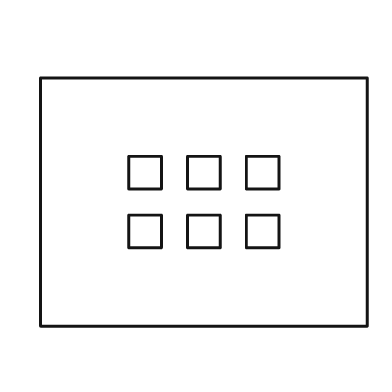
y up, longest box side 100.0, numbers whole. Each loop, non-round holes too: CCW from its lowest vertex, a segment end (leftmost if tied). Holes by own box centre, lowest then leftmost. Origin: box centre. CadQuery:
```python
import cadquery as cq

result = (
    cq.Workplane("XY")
    .moveTo(-50.0, -38.0)
    .lineTo(50.0, -38.0)
    .lineTo(50.0, 38.0)
    .lineTo(-50.0, 38.0)
    .close()
    .moveTo(-23.0, -14.0)
    .lineTo(-13.0, -14.0)
    .lineTo(-13.0, -4.0)
    .lineTo(-23.0, -4.0)
    .close()
    .moveTo(-5.0, -14.0)
    .lineTo(5.0, -14.0)
    .lineTo(5.0, -4.0)
    .lineTo(-5.0, -4.0)
    .close()
    .moveTo(13.0, -14.0)
    .lineTo(23.0, -14.0)
    .lineTo(23.0, -4.0)
    .lineTo(13.0, -4.0)
    .close()
    .moveTo(-23.0, 4.0)
    .lineTo(-13.0, 4.0)
    .lineTo(-13.0, 14.0)
    .lineTo(-23.0, 14.0)
    .close()
    .moveTo(-5.0, 4.0)
    .lineTo(5.0, 4.0)
    .lineTo(5.0, 14.0)
    .lineTo(-5.0, 14.0)
    .close()
    .moveTo(13.0, 4.0)
    .lineTo(23.0, 4.0)
    .lineTo(23.0, 14.0)
    .lineTo(13.0, 14.0)
    .close()
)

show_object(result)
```